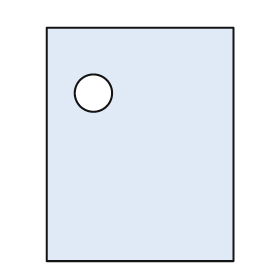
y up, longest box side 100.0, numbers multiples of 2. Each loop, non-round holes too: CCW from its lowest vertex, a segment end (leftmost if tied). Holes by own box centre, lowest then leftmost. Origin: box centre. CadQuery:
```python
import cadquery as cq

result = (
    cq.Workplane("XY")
    .moveTo(-40.0, -50.0)
    .lineTo(40.0, -50.0)
    .lineTo(40.0, 50.0)
    .lineTo(-40.0, 50.0)
    .close()
    .moveTo(-20.0, 22.0)
    .circle(8.0)
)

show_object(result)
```